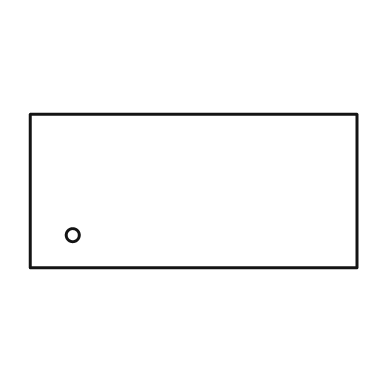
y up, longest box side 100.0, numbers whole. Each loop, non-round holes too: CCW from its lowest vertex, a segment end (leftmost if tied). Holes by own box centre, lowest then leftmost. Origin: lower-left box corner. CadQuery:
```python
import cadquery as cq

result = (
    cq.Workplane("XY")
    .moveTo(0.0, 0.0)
    .lineTo(100.0, 0.0)
    .lineTo(100.0, 47.0)
    .lineTo(0.0, 47.0)
    .close()
    .moveTo(13.0, 10.0)
    .circle(2.0)
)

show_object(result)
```